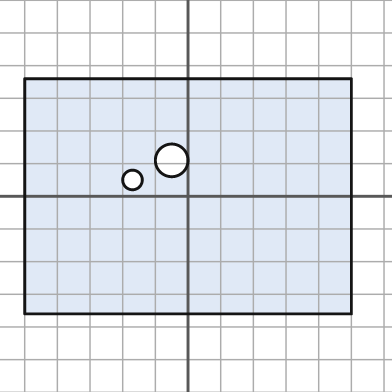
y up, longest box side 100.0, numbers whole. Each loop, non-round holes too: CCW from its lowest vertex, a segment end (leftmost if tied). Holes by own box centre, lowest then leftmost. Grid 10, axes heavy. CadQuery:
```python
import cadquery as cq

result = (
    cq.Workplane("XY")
    .moveTo(-50.0, -36.0)
    .lineTo(50.0, -36.0)
    .lineTo(50.0, 36.0)
    .lineTo(-50.0, 36.0)
    .close()
    .moveTo(-17.0, 5.0)
    .circle(3.0)
    .moveTo(-5.0, 11.0)
    .circle(5.0)
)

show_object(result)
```